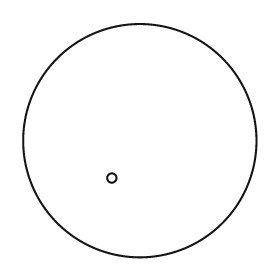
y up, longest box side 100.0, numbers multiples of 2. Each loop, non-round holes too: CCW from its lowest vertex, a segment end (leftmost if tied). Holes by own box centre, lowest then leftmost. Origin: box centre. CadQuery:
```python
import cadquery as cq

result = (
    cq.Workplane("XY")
    .moveTo(0.0, 0.0)
    .circle(50.0)
    .moveTo(-12.0, -16.0)
    .circle(2.0)
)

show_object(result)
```